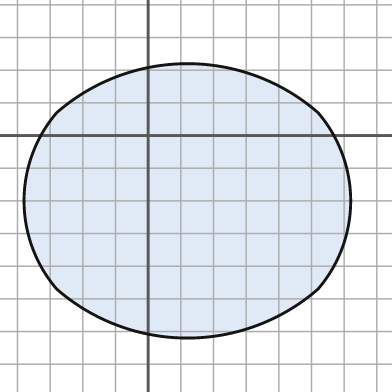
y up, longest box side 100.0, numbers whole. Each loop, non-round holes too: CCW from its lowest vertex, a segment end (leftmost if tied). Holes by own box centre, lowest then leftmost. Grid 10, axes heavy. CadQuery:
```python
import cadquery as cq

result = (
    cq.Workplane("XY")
    .moveTo(-28.0, -47.0)
    .threePointArc((12.0, -62.0), (52.0, -47.0))
    .threePointArc((62.0, -20.0), (52.0, 7.0))
    .threePointArc((12.0, 22.0), (-28.0, 7.0))
    .threePointArc((-38.0, -20.0), (-28.0, -47.0))
    .close()
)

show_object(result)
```